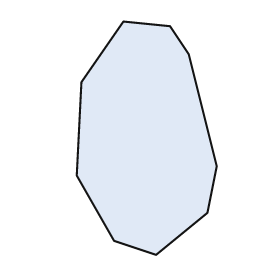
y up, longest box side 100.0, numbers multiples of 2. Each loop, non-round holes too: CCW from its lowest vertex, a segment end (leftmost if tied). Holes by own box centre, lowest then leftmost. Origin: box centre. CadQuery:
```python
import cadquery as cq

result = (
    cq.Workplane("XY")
    .moveTo(4.0, -50.0)
    .lineTo(26.0, -32.0)
    .lineTo(30.0, -12.0)
    .lineTo(18.0, 36.0)
    .lineTo(10.0, 48.0)
    .lineTo(-10.0, 50.0)
    .lineTo(-28.0, 24.0)
    .lineTo(-30.0, -16.0)
    .lineTo(-14.0, -44.0)
    .close()
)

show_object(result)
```